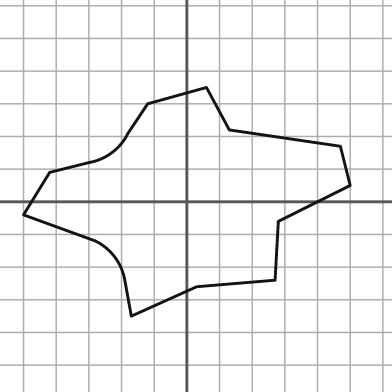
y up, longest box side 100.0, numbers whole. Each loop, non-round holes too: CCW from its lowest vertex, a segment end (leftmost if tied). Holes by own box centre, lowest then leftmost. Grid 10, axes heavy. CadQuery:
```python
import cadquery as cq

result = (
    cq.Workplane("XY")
    .moveTo(-17.0, -35.0)
    .lineTo(3.0, -26.0)
    .lineTo(27.0, -24.0)
    .lineTo(28.0, -6.0)
    .lineTo(50.0, 5.0)
    .lineTo(47.0, 17.0)
    .lineTo(13.0, 22.0)
    .lineTo(6.0, 35.0)
    .lineTo(-12.0, 30.0)
    .lineTo(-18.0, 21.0)
    .threePointArc((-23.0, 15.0), (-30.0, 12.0))
    .lineTo(-42.0, 9.0)
    .lineTo(-50.0, -4.0)
    .lineTo(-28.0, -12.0)
    .threePointArc((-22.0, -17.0), (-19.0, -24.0))
    .close()
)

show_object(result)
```